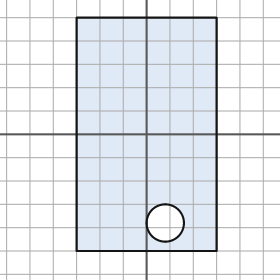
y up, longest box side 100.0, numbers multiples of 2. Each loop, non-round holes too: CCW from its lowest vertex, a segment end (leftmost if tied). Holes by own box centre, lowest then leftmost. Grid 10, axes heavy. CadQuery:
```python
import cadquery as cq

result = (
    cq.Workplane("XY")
    .moveTo(-30.0, -50.0)
    .lineTo(30.0, -50.0)
    .lineTo(30.0, 50.0)
    .lineTo(-30.0, 50.0)
    .close()
    .moveTo(8.0, -38.0)
    .circle(8.0)
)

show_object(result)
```